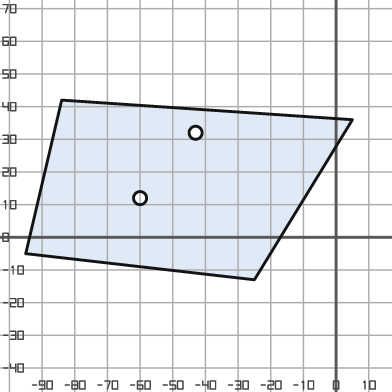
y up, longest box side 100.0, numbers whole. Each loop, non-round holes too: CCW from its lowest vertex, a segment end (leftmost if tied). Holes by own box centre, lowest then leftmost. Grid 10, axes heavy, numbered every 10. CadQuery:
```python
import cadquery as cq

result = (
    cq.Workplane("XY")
    .moveTo(-25.0, -13.0)
    .lineTo(5.0, 36.0)
    .lineTo(-84.0, 42.0)
    .lineTo(-95.0, -5.0)
    .close()
    .moveTo(-60.0, 12.0)
    .circle(2.0)
    .moveTo(-43.0, 32.0)
    .circle(2.0)
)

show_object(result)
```